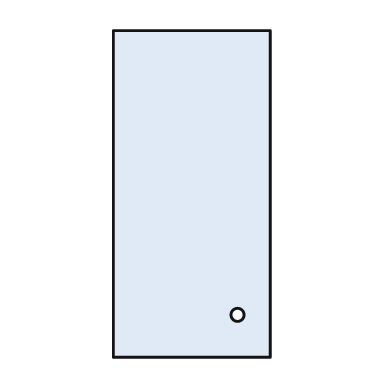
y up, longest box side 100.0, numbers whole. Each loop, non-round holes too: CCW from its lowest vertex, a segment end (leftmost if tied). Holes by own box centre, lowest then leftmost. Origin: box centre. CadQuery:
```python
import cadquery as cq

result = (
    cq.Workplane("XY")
    .moveTo(-24.0, -50.0)
    .lineTo(24.0, -50.0)
    .lineTo(24.0, 50.0)
    .lineTo(-24.0, 50.0)
    .close()
    .moveTo(14.0, -37.0)
    .circle(2.0)
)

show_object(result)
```